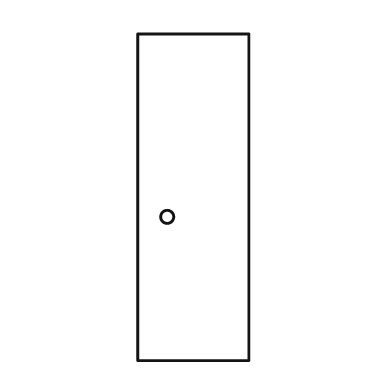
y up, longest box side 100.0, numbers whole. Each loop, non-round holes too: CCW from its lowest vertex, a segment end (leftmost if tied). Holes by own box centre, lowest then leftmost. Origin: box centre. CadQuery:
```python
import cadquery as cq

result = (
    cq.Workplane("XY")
    .moveTo(-17.0, -50.0)
    .lineTo(17.0, -50.0)
    .lineTo(17.0, 50.0)
    .lineTo(-17.0, 50.0)
    .close()
    .moveTo(-8.0, -6.0)
    .circle(2.0)
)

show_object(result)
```